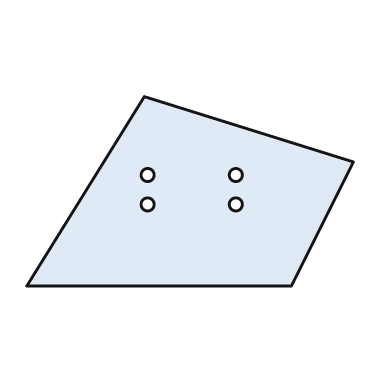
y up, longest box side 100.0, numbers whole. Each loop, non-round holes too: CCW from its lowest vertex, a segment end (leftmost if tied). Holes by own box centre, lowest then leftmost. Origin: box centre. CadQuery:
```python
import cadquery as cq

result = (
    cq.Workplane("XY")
    .moveTo(-50.0, -29.0)
    .lineTo(31.0, -29.0)
    .lineTo(50.0, 9.0)
    .lineTo(-14.0, 29.0)
    .close()
    .moveTo(-13.0, -4.0)
    .circle(2.0)
    .moveTo(14.0, -4.0)
    .circle(2.0)
    .moveTo(-13.0, 5.0)
    .circle(2.0)
    .moveTo(14.0, 5.0)
    .circle(2.0)
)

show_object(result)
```